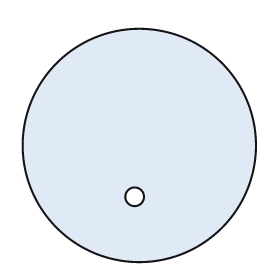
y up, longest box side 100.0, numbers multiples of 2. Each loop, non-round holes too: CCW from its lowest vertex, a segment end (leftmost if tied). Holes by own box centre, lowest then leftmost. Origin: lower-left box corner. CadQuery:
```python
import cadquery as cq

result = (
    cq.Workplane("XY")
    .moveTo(50.0, 50.0)
    .circle(50.0)
    .moveTo(48.0, 28.0)
    .circle(4.0)
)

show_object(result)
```